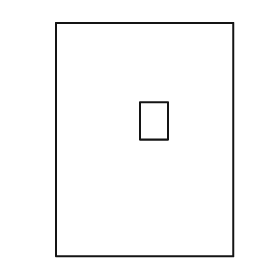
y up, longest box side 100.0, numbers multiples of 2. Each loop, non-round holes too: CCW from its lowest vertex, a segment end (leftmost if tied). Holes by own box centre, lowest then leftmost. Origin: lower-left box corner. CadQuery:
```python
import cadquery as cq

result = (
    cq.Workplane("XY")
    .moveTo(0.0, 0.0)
    .lineTo(76.0, 0.0)
    .lineTo(76.0, 100.0)
    .lineTo(0.0, 100.0)
    .close()
    .moveTo(36.0, 50.0)
    .lineTo(48.0, 50.0)
    .lineTo(48.0, 66.0)
    .lineTo(36.0, 66.0)
    .close()
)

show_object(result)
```